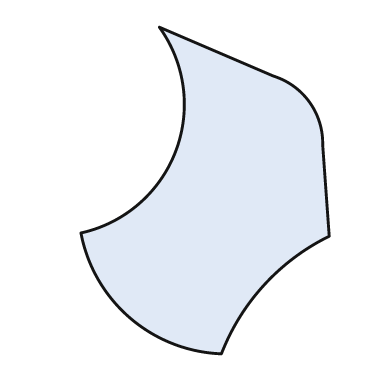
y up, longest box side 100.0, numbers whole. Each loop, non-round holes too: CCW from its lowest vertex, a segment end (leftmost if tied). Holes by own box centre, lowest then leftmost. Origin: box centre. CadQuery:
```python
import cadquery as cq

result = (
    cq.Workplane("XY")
    .moveTo(5.0, -50.0)
    .threePointArc((18.0, -29.0), (38.0, -14.0))
    .lineTo(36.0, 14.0)
    .threePointArc((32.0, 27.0), (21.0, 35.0))
    .lineTo(-14.0, 50.0)
    .threePointArc((-9.0, 12.0), (-38.0, -13.0))
    .threePointArc((-23.0, -39.0), (5.0, -50.0))
    .close()
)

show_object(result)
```